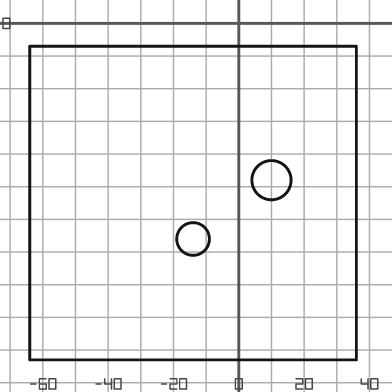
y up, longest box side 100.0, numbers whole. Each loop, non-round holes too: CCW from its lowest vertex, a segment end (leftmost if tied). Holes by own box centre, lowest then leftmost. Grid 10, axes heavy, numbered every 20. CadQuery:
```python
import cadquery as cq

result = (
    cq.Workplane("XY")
    .moveTo(-64.0, -103.0)
    .lineTo(36.0, -103.0)
    .lineTo(36.0, -7.0)
    .lineTo(-64.0, -7.0)
    .close()
    .moveTo(-14.0, -66.0)
    .circle(5.0)
    .moveTo(10.0, -48.0)
    .circle(6.0)
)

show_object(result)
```